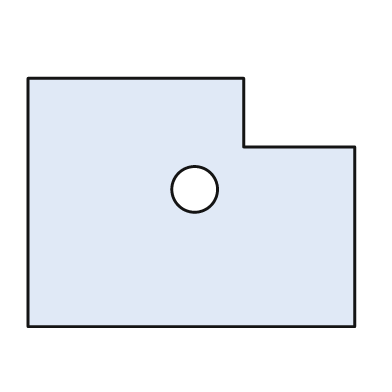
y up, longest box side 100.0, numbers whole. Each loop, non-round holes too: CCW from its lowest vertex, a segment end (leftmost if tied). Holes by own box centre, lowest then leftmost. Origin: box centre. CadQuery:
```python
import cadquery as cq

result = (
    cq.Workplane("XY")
    .moveTo(-50.0, -38.0)
    .lineTo(50.0, -38.0)
    .lineTo(50.0, 17.0)
    .lineTo(16.0, 17.0)
    .lineTo(16.0, 38.0)
    .lineTo(-50.0, 38.0)
    .close()
    .moveTo(1.0, 4.0)
    .circle(7.0)
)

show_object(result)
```